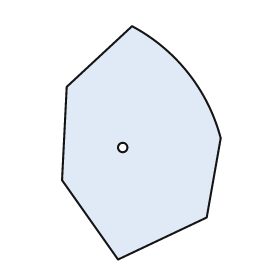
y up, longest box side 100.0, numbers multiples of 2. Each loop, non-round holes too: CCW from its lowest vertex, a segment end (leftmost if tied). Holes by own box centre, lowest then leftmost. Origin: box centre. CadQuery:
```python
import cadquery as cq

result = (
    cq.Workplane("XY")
    .moveTo(-10.0, -50.0)
    .lineTo(28.0, -32.0)
    .lineTo(34.0, 2.0)
    .threePointArc((20.0, 30.0), (-4.0, 50.0))
    .lineTo(-32.0, 24.0)
    .lineTo(-34.0, -16.0)
    .close()
    .moveTo(-8.0, -2.0)
    .circle(2.0)
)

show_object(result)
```